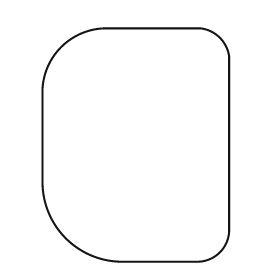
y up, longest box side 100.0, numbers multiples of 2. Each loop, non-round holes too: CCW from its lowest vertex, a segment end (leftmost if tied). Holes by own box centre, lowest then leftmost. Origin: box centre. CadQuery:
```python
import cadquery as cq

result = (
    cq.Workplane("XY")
    .moveTo(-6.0, -50.0)
    .lineTo(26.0, -50.0)
    .threePointArc((36.0, -46.0), (40.0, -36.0))
    .lineTo(40.0, 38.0)
    .threePointArc((36.0, 46.0), (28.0, 50.0))
    .lineTo(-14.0, 50.0)
    .threePointArc((-32.0, 42.0), (-40.0, 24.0))
    .lineTo(-40.0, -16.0)
    .threePointArc((-30.0, -40.0), (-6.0, -50.0))
    .close()
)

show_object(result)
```